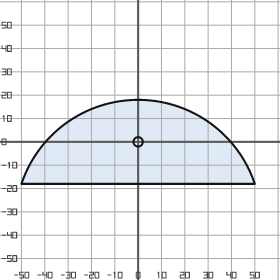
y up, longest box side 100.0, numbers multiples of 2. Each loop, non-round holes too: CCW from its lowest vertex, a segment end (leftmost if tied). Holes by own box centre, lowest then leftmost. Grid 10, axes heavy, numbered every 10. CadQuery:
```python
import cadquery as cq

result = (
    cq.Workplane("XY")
    .moveTo(-50.0, -18.0)
    .lineTo(50.0, -18.0)
    .threePointArc((0.0, 18.0), (-50.0, -18.0))
    .close()
    .moveTo(0.0, 0.0)
    .circle(2.0)
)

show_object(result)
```